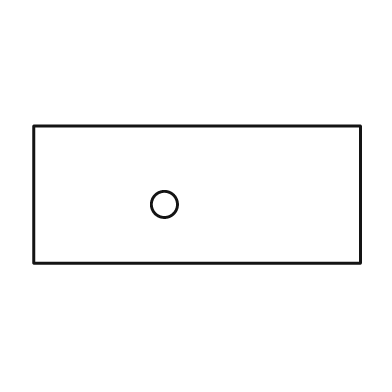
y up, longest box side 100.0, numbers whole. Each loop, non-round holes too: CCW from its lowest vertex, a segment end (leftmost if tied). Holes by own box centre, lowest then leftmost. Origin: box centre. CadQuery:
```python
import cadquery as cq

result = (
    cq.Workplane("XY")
    .moveTo(-50.0, -21.0)
    .lineTo(50.0, -21.0)
    .lineTo(50.0, 21.0)
    .lineTo(-50.0, 21.0)
    .close()
    .moveTo(-10.0, -3.0)
    .circle(4.0)
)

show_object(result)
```